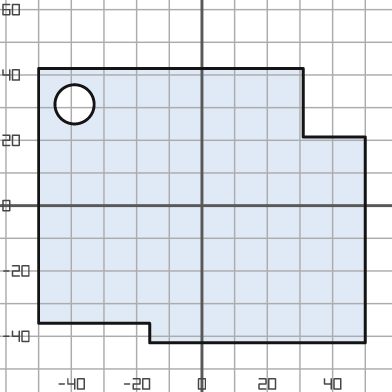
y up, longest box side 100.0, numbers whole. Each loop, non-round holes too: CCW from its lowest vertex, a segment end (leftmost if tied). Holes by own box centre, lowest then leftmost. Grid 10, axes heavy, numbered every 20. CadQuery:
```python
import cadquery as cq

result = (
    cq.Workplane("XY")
    .moveTo(-16.0, -42.0)
    .lineTo(50.0, -42.0)
    .lineTo(50.0, 21.0)
    .lineTo(31.0, 21.0)
    .lineTo(31.0, 42.0)
    .lineTo(-50.0, 42.0)
    .lineTo(-50.0, -36.0)
    .lineTo(-16.0, -36.0)
    .close()
    .moveTo(-39.0, 31.0)
    .circle(6.0)
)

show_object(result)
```